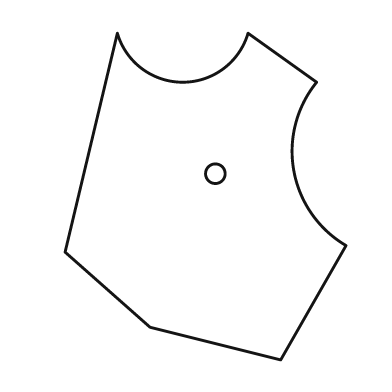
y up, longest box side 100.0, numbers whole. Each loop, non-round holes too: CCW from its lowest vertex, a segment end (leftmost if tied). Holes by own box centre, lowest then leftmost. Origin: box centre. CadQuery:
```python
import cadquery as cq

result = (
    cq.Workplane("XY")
    .moveTo(23.0, -50.0)
    .lineTo(43.0, -15.0)
    .threePointArc((27.0, 8.0), (34.0, 35.0))
    .lineTo(13.0, 50.0)
    .threePointArc((-7.0, 35.0), (-27.0, 50.0))
    .lineTo(-43.0, -17.0)
    .lineTo(-17.0, -40.0)
    .close()
    .moveTo(3.0, 7.0)
    .circle(3.0)
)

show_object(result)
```